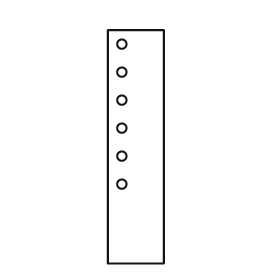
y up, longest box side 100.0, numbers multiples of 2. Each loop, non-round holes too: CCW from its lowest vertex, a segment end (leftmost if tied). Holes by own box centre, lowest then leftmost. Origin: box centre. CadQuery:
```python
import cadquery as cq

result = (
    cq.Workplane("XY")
    .moveTo(-12.0, -50.0)
    .lineTo(12.0, -50.0)
    .lineTo(12.0, 50.0)
    .lineTo(-12.0, 50.0)
    .close()
    .moveTo(-6.0, -16.0)
    .circle(2.0)
    .moveTo(-6.0, -4.0)
    .circle(2.0)
    .moveTo(-6.0, 8.0)
    .circle(2.0)
    .moveTo(-6.0, 20.0)
    .circle(2.0)
    .moveTo(-6.0, 32.0)
    .circle(2.0)
    .moveTo(-6.0, 44.0)
    .circle(2.0)
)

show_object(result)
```